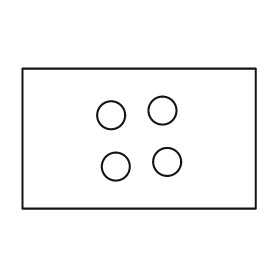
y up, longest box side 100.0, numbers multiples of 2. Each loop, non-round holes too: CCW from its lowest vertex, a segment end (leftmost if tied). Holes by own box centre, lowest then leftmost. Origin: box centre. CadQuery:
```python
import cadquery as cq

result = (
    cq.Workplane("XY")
    .moveTo(-50.0, -30.0)
    .lineTo(50.0, -30.0)
    .lineTo(50.0, 30.0)
    .lineTo(-50.0, 30.0)
    .close()
    .moveTo(-10.0, -12.0)
    .circle(6.0)
    .moveTo(12.0, -10.0)
    .circle(6.0)
    .moveTo(-12.0, 10.0)
    .circle(6.0)
    .moveTo(10.0, 12.0)
    .circle(6.0)
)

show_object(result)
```